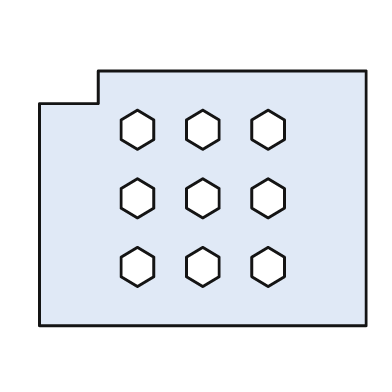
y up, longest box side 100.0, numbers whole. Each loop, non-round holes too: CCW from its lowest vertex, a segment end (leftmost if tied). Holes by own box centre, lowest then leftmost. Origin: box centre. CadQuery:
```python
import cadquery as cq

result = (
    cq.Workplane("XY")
    .moveTo(-50.0, -39.0)
    .lineTo(50.0, -39.0)
    .lineTo(50.0, 39.0)
    .lineTo(-32.0, 39.0)
    .lineTo(-32.0, 29.0)
    .lineTo(-50.0, 29.0)
    .close()
    .moveTo(-20.0, -27.0)
    .lineTo(-15.0, -24.0)
    .lineTo(-15.0, -18.0)
    .lineTo(-20.0, -15.0)
    .lineTo(-25.0, -18.0)
    .lineTo(-25.0, -24.0)
    .close()
    .moveTo(0.0, -27.0)
    .lineTo(5.0, -24.0)
    .lineTo(5.0, -18.0)
    .lineTo(0.0, -15.0)
    .lineTo(-5.0, -18.0)
    .lineTo(-5.0, -24.0)
    .close()
    .moveTo(20.0, -27.0)
    .lineTo(25.0, -24.0)
    .lineTo(25.0, -18.0)
    .lineTo(20.0, -15.0)
    .lineTo(15.0, -18.0)
    .lineTo(15.0, -24.0)
    .close()
    .moveTo(-20.0, -6.0)
    .lineTo(-15.0, -3.0)
    .lineTo(-15.0, 3.0)
    .lineTo(-20.0, 6.0)
    .lineTo(-25.0, 3.0)
    .lineTo(-25.0, -3.0)
    .close()
    .moveTo(0.0, -6.0)
    .lineTo(5.0, -3.0)
    .lineTo(5.0, 3.0)
    .lineTo(0.0, 6.0)
    .lineTo(-5.0, 3.0)
    .lineTo(-5.0, -3.0)
    .close()
    .moveTo(20.0, -6.0)
    .lineTo(25.0, -3.0)
    .lineTo(25.0, 3.0)
    .lineTo(20.0, 6.0)
    .lineTo(15.0, 3.0)
    .lineTo(15.0, -3.0)
    .close()
    .moveTo(-20.0, 15.0)
    .lineTo(-15.0, 18.0)
    .lineTo(-15.0, 24.0)
    .lineTo(-20.0, 27.0)
    .lineTo(-25.0, 24.0)
    .lineTo(-25.0, 18.0)
    .close()
    .moveTo(0.0, 15.0)
    .lineTo(5.0, 18.0)
    .lineTo(5.0, 24.0)
    .lineTo(0.0, 27.0)
    .lineTo(-5.0, 24.0)
    .lineTo(-5.0, 18.0)
    .close()
    .moveTo(20.0, 15.0)
    .lineTo(25.0, 18.0)
    .lineTo(25.0, 24.0)
    .lineTo(20.0, 27.0)
    .lineTo(15.0, 24.0)
    .lineTo(15.0, 18.0)
    .close()
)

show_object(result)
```